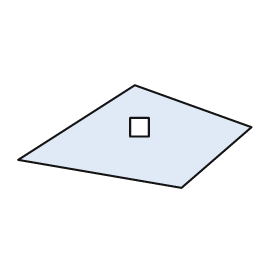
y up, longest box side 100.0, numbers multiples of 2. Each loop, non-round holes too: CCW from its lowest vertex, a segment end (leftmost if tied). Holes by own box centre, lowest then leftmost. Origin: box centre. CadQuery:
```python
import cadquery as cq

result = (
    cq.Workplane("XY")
    .moveTo(20.0, -22.0)
    .lineTo(50.0, 4.0)
    .lineTo(0.0, 22.0)
    .lineTo(-50.0, -10.0)
    .close()
    .moveTo(-2.0, 0.0)
    .lineTo(6.0, 0.0)
    .lineTo(6.0, 8.0)
    .lineTo(-2.0, 8.0)
    .close()
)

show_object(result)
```